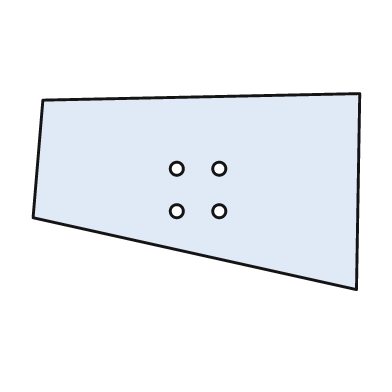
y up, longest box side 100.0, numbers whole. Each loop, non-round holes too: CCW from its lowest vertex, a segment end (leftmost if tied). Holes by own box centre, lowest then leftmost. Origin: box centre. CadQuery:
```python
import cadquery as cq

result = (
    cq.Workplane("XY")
    .moveTo(49.0, -30.0)
    .lineTo(50.0, 30.0)
    .lineTo(-47.0, 28.0)
    .lineTo(-50.0, -8.0)
    .close()
    .moveTo(-6.0, -6.0)
    .circle(2.0)
    .moveTo(7.0, -6.0)
    .circle(2.0)
    .moveTo(-6.0, 7.0)
    .circle(2.0)
    .moveTo(7.0, 7.0)
    .circle(2.0)
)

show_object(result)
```